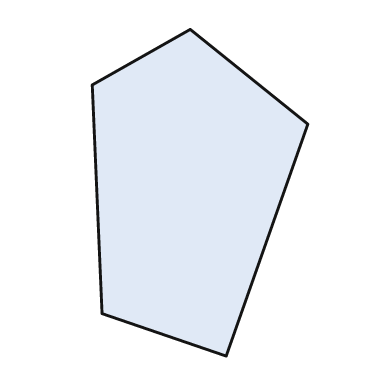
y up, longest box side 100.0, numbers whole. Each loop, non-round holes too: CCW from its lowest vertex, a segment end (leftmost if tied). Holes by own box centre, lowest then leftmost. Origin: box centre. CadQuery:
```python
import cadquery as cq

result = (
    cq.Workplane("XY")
    .moveTo(8.0, -50.0)
    .lineTo(33.0, 21.0)
    .lineTo(-3.0, 50.0)
    .lineTo(-33.0, 33.0)
    .lineTo(-30.0, -37.0)
    .close()
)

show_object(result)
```